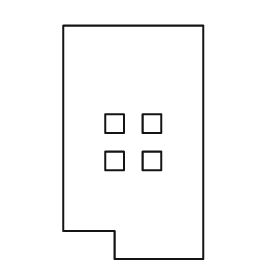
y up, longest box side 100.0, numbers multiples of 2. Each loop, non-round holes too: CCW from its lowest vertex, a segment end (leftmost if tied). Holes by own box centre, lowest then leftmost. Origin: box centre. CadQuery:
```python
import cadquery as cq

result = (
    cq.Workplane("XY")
    .moveTo(-8.0, -50.0)
    .lineTo(30.0, -50.0)
    .lineTo(30.0, 50.0)
    .lineTo(-30.0, 50.0)
    .lineTo(-30.0, -38.0)
    .lineTo(-8.0, -38.0)
    .close()
    .moveTo(-12.0, -12.0)
    .lineTo(-4.0, -12.0)
    .lineTo(-4.0, -4.0)
    .lineTo(-12.0, -4.0)
    .close()
    .moveTo(4.0, -12.0)
    .lineTo(12.0, -12.0)
    .lineTo(12.0, -4.0)
    .lineTo(4.0, -4.0)
    .close()
    .moveTo(-12.0, 4.0)
    .lineTo(-4.0, 4.0)
    .lineTo(-4.0, 12.0)
    .lineTo(-12.0, 12.0)
    .close()
    .moveTo(4.0, 4.0)
    .lineTo(12.0, 4.0)
    .lineTo(12.0, 12.0)
    .lineTo(4.0, 12.0)
    .close()
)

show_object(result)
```